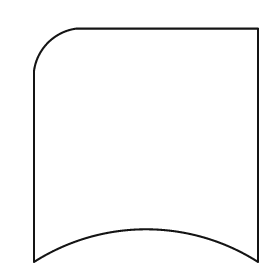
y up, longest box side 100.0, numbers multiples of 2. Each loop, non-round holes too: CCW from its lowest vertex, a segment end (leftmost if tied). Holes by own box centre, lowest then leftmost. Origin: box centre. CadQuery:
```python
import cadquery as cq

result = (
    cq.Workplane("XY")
    .moveTo(-48.0, -50.0)
    .threePointArc((0.0, -36.0), (48.0, -50.0))
    .lineTo(48.0, 50.0)
    .lineTo(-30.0, 50.0)
    .threePointArc((-42.0, 44.0), (-48.0, 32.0))
    .close()
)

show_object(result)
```